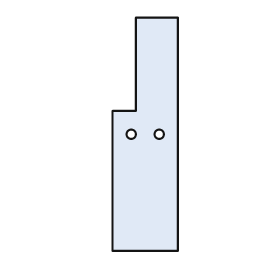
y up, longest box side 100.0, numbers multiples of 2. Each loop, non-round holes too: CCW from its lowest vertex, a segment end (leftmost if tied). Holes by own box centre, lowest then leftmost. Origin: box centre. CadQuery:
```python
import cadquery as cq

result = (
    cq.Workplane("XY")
    .moveTo(-14.0, -50.0)
    .lineTo(14.0, -50.0)
    .lineTo(14.0, 50.0)
    .lineTo(-4.0, 50.0)
    .lineTo(-4.0, 10.0)
    .lineTo(-14.0, 10.0)
    .close()
    .moveTo(-6.0, 0.0)
    .circle(2.0)
    .moveTo(6.0, 0.0)
    .circle(2.0)
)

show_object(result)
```